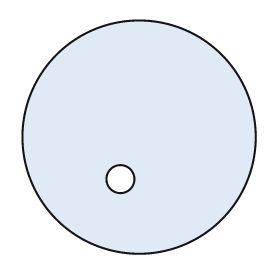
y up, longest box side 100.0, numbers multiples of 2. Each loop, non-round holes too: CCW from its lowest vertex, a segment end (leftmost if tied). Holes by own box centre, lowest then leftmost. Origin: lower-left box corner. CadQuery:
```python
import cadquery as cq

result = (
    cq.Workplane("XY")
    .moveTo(50.0, 50.0)
    .circle(50.0)
    .moveTo(42.0, 32.0)
    .circle(6.0)
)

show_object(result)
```